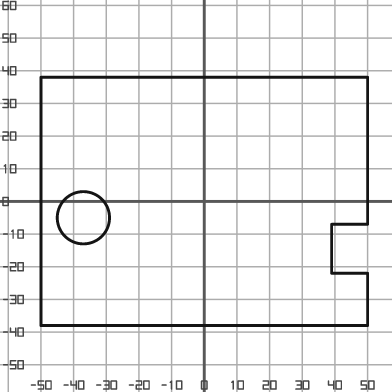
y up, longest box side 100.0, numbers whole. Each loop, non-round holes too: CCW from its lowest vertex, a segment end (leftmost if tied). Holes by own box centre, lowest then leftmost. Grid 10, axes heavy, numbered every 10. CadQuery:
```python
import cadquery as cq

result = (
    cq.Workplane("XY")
    .moveTo(-50.0, -38.0)
    .lineTo(50.0, -38.0)
    .lineTo(50.0, -22.0)
    .lineTo(39.0, -22.0)
    .lineTo(39.0, -7.0)
    .lineTo(50.0, -7.0)
    .lineTo(50.0, 38.0)
    .lineTo(-50.0, 38.0)
    .close()
    .moveTo(-37.0, -5.0)
    .circle(8.0)
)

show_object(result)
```